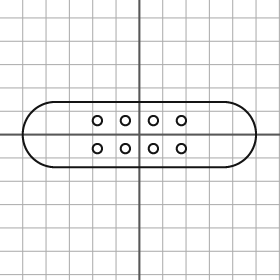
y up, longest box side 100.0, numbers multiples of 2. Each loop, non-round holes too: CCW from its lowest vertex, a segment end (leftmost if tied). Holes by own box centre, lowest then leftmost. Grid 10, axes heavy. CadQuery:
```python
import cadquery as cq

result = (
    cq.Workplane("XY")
    .moveTo(-36.0, -14.0)
    .lineTo(36.0, -14.0)
    .threePointArc((50.0, 0.0), (36.0, 14.0))
    .lineTo(-36.0, 14.0)
    .threePointArc((-50.0, 0.0), (-36.0, -14.0))
    .close()
    .moveTo(-18.0, -6.0)
    .circle(2.0)
    .moveTo(-6.0, -6.0)
    .circle(2.0)
    .moveTo(6.0, -6.0)
    .circle(2.0)
    .moveTo(18.0, -6.0)
    .circle(2.0)
    .moveTo(-18.0, 6.0)
    .circle(2.0)
    .moveTo(-6.0, 6.0)
    .circle(2.0)
    .moveTo(6.0, 6.0)
    .circle(2.0)
    .moveTo(18.0, 6.0)
    .circle(2.0)
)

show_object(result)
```